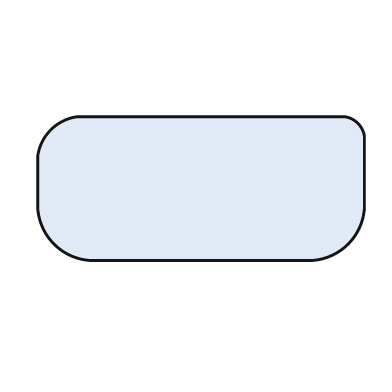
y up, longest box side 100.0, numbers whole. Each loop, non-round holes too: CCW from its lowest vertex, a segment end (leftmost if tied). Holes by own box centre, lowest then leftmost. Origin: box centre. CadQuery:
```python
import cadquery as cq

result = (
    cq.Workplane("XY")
    .moveTo(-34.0, -22.0)
    .lineTo(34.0, -22.0)
    .threePointArc((45.0, -17.0), (50.0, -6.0))
    .lineTo(50.0, 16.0)
    .threePointArc((48.0, 20.0), (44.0, 22.0))
    .lineTo(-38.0, 22.0)
    .threePointArc((-46.0, 18.0), (-50.0, 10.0))
    .lineTo(-50.0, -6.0)
    .threePointArc((-45.0, -17.0), (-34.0, -22.0))
    .close()
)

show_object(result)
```